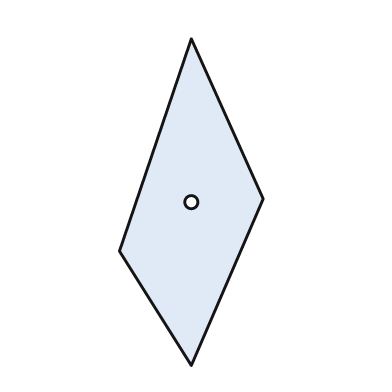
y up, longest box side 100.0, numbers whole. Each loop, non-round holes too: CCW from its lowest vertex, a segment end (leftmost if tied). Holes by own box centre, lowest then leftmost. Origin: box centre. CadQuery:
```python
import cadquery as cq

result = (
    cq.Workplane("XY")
    .moveTo(0.0, -50.0)
    .lineTo(22.0, 1.0)
    .lineTo(0.0, 50.0)
    .lineTo(-22.0, -15.0)
    .close()
    .moveTo(0.0, 0.0)
    .circle(2.0)
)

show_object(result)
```